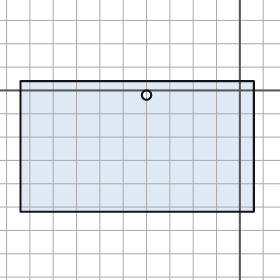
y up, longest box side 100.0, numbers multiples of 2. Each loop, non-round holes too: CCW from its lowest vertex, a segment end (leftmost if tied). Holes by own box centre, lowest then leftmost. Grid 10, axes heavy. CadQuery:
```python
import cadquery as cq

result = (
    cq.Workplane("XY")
    .moveTo(-94.0, -52.0)
    .lineTo(6.0, -52.0)
    .lineTo(6.0, 4.0)
    .lineTo(-94.0, 4.0)
    .close()
    .moveTo(-40.0, -2.0)
    .circle(2.0)
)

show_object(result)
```